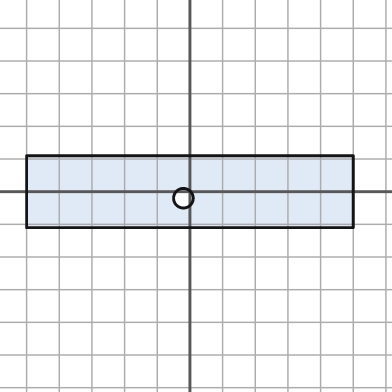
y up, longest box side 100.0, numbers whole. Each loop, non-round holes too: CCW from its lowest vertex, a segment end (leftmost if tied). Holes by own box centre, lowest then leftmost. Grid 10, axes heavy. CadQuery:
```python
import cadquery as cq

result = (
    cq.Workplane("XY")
    .moveTo(-50.0, -11.0)
    .lineTo(50.0, -11.0)
    .lineTo(50.0, 11.0)
    .lineTo(-50.0, 11.0)
    .close()
    .moveTo(-2.0, -2.0)
    .circle(3.0)
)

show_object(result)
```